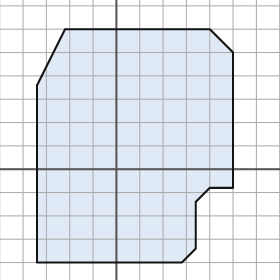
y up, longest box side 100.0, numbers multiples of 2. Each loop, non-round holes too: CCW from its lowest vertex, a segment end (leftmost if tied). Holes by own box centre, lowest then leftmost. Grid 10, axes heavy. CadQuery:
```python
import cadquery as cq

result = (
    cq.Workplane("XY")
    .moveTo(-34.0, -40.0)
    .lineTo(28.0, -40.0)
    .lineTo(34.0, -34.0)
    .lineTo(34.0, -14.0)
    .lineTo(40.0, -8.0)
    .lineTo(50.0, -8.0)
    .lineTo(50.0, 50.0)
    .lineTo(40.0, 60.0)
    .lineTo(-22.0, 60.0)
    .lineTo(-34.0, 36.0)
    .close()
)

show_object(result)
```